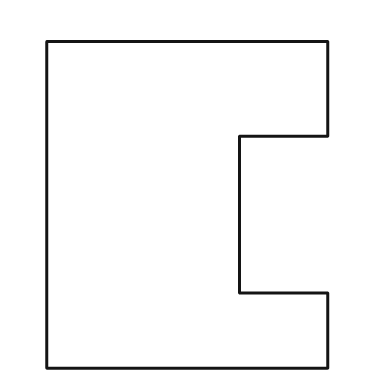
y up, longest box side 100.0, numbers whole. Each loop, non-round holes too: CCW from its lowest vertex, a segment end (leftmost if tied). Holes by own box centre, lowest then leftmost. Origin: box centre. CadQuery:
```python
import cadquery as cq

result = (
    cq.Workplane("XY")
    .moveTo(-43.0, -50.0)
    .lineTo(43.0, -50.0)
    .lineTo(43.0, -27.0)
    .lineTo(16.0, -27.0)
    .lineTo(16.0, 21.0)
    .lineTo(43.0, 21.0)
    .lineTo(43.0, 50.0)
    .lineTo(-43.0, 50.0)
    .close()
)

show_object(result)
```